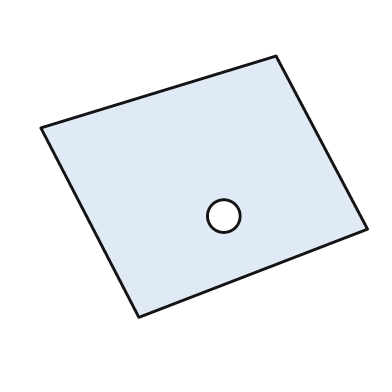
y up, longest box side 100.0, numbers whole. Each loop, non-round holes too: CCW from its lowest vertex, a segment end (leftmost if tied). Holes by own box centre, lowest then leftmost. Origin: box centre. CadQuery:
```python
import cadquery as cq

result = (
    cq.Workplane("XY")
    .moveTo(-20.0, -40.0)
    .lineTo(50.0, -13.0)
    .lineTo(22.0, 40.0)
    .lineTo(-50.0, 18.0)
    .close()
    .moveTo(6.0, -9.0)
    .circle(5.0)
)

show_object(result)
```